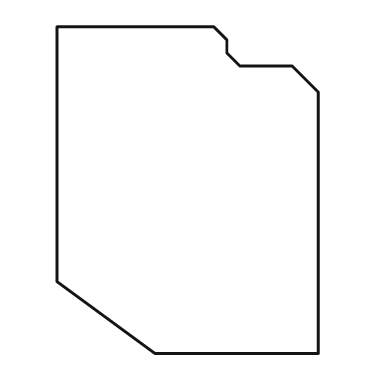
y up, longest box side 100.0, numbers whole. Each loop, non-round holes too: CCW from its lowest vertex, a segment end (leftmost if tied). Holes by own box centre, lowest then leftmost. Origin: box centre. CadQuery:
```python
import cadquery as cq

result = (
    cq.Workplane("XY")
    .moveTo(-10.0, -50.0)
    .lineTo(40.0, -50.0)
    .lineTo(40.0, 30.0)
    .lineTo(32.0, 38.0)
    .lineTo(16.0, 38.0)
    .lineTo(12.0, 42.0)
    .lineTo(12.0, 46.0)
    .lineTo(8.0, 50.0)
    .lineTo(-40.0, 50.0)
    .lineTo(-40.0, -28.0)
    .close()
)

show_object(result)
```